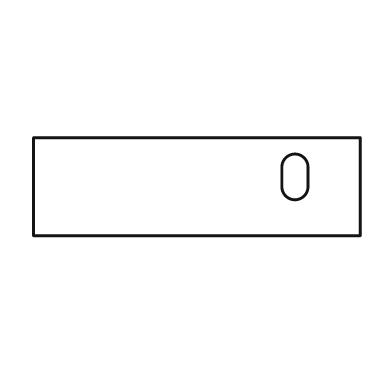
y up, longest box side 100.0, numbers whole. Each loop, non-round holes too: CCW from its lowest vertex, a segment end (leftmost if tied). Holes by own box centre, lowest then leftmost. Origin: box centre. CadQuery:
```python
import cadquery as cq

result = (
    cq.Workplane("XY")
    .moveTo(-50.0, -15.0)
    .lineTo(50.0, -15.0)
    .lineTo(50.0, 15.0)
    .lineTo(-50.0, 15.0)
    .close()
    .moveTo(26.0, 0.0)
    .threePointArc((30.0, -4.0), (34.0, 0.0))
    .lineTo(34.0, 6.0)
    .threePointArc((30.0, 10.0), (26.0, 6.0))
    .close()
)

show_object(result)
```